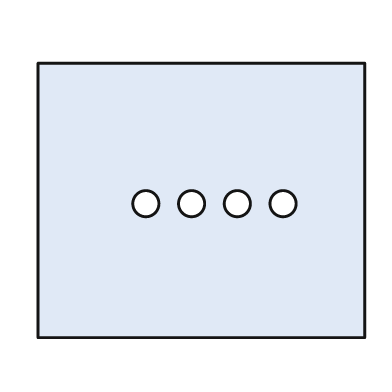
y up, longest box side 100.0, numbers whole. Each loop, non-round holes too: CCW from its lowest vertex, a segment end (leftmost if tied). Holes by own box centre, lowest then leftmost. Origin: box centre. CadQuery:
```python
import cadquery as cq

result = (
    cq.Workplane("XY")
    .moveTo(-50.0, -42.0)
    .lineTo(50.0, -42.0)
    .lineTo(50.0, 42.0)
    .lineTo(-50.0, 42.0)
    .close()
    .moveTo(-17.0, -1.0)
    .circle(4.0)
    .moveTo(-3.0, -1.0)
    .circle(4.0)
    .moveTo(11.0, -1.0)
    .circle(4.0)
    .moveTo(25.0, -1.0)
    .circle(4.0)
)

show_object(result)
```